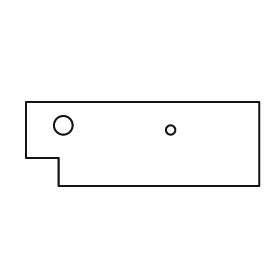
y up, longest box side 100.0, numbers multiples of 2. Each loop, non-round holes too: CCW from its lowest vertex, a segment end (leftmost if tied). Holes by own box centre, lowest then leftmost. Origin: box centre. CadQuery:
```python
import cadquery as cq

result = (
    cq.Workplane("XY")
    .moveTo(-36.0, -18.0)
    .lineTo(50.0, -18.0)
    .lineTo(50.0, 18.0)
    .lineTo(-50.0, 18.0)
    .lineTo(-50.0, -6.0)
    .lineTo(-36.0, -6.0)
    .close()
    .moveTo(12.0, 6.0)
    .circle(2.0)
    .moveTo(-34.0, 8.0)
    .circle(4.0)
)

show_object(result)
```